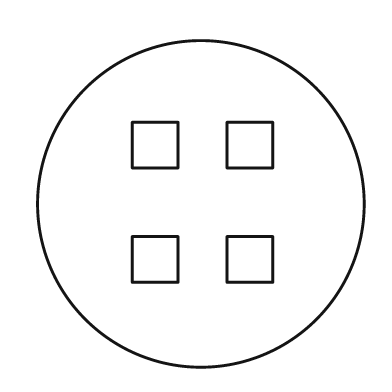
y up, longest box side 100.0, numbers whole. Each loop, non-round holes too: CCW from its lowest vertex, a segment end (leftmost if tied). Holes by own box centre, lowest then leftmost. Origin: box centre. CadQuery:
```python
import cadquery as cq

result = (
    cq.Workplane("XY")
    .moveTo(0.0, 0.0)
    .circle(50.0)
    .moveTo(-21.0, -24.0)
    .lineTo(-7.0, -24.0)
    .lineTo(-7.0, -10.0)
    .lineTo(-21.0, -10.0)
    .close()
    .moveTo(8.0, -24.0)
    .lineTo(22.0, -24.0)
    .lineTo(22.0, -10.0)
    .lineTo(8.0, -10.0)
    .close()
    .moveTo(-21.0, 11.0)
    .lineTo(-7.0, 11.0)
    .lineTo(-7.0, 25.0)
    .lineTo(-21.0, 25.0)
    .close()
    .moveTo(8.0, 11.0)
    .lineTo(22.0, 11.0)
    .lineTo(22.0, 25.0)
    .lineTo(8.0, 25.0)
    .close()
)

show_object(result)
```